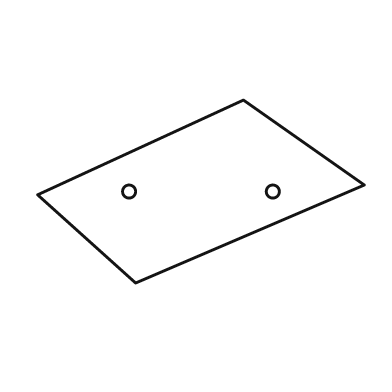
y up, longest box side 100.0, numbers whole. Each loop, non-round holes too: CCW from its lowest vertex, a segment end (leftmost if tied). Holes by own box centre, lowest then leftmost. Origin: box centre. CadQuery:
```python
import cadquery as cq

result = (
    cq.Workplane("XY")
    .moveTo(-20.0, -28.0)
    .lineTo(50.0, 2.0)
    .lineTo(13.0, 28.0)
    .lineTo(-50.0, -1.0)
    .close()
    .moveTo(-22.0, 0.0)
    .circle(2.0)
    .moveTo(22.0, 0.0)
    .circle(2.0)
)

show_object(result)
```